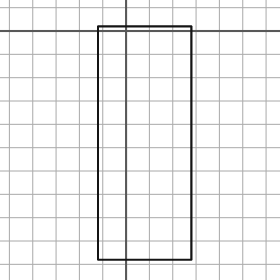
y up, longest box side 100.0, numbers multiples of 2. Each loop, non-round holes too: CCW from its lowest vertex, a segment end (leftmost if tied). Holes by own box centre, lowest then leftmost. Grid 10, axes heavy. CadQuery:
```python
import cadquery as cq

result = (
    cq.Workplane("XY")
    .moveTo(-12.0, -98.0)
    .lineTo(28.0, -98.0)
    .lineTo(28.0, 2.0)
    .lineTo(-12.0, 2.0)
    .close()
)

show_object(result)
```